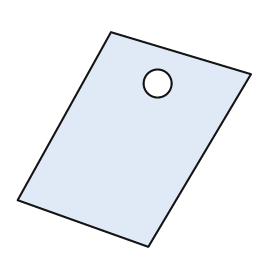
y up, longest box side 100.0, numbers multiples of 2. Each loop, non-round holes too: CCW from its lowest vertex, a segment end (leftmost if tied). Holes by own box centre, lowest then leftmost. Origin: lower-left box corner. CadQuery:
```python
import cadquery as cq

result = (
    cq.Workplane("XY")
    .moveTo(56.0, 0.0)
    .lineTo(100.0, 74.0)
    .lineTo(40.0, 92.0)
    .lineTo(0.0, 20.0)
    .close()
    .moveTo(60.0, 70.0)
    .circle(6.0)
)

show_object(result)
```